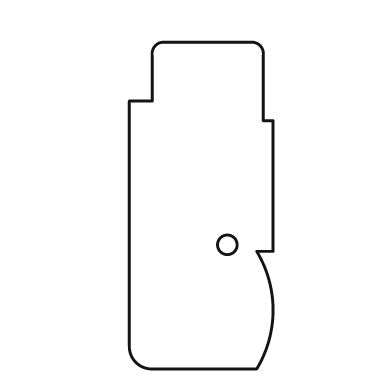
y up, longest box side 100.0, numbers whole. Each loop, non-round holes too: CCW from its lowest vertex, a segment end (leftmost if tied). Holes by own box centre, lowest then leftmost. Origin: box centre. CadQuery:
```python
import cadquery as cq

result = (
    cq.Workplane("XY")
    .moveTo(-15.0, -50.0)
    .lineTo(17.0, -50.0)
    .threePointArc((22.0, -32.0), (17.0, -14.0))
    .lineTo(22.0, -14.0)
    .lineTo(22.0, 26.0)
    .lineTo(19.0, 26.0)
    .lineTo(19.0, 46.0)
    .threePointArc((18.0, 49.0), (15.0, 50.0))
    .lineTo(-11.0, 50.0)
    .threePointArc((-14.0, 49.0), (-15.0, 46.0))
    .lineTo(-15.0, 32.0)
    .lineTo(-22.0, 32.0)
    .lineTo(-22.0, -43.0)
    .threePointArc((-20.0, -48.0), (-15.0, -50.0))
    .close()
    .moveTo(8.0, -12.0)
    .circle(3.0)
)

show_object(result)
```